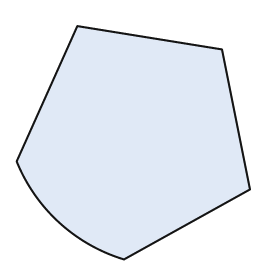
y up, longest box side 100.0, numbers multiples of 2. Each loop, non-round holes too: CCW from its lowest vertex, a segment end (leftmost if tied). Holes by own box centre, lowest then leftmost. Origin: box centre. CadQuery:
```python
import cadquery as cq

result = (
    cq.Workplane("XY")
    .moveTo(-4.0, -50.0)
    .lineTo(50.0, -20.0)
    .lineTo(38.0, 40.0)
    .lineTo(-24.0, 50.0)
    .lineTo(-50.0, -8.0)
    .threePointArc((-32.0, -34.0), (-4.0, -50.0))
    .close()
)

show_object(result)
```